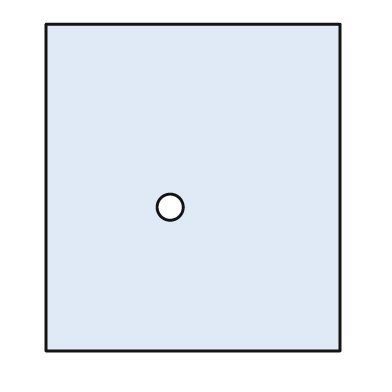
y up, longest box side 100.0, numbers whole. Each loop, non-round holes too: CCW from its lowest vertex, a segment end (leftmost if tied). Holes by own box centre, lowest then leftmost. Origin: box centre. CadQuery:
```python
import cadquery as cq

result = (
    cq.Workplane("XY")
    .moveTo(-45.0, -50.0)
    .lineTo(45.0, -50.0)
    .lineTo(45.0, 50.0)
    .lineTo(-45.0, 50.0)
    .close()
    .moveTo(-7.0, -6.0)
    .circle(4.0)
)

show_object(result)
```